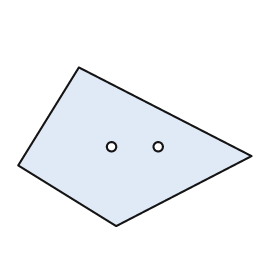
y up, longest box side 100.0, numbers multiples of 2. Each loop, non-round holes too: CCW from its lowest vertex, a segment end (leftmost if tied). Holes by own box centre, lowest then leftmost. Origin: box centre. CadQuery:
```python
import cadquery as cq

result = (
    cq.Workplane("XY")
    .moveTo(-8.0, -34.0)
    .lineTo(50.0, -4.0)
    .lineTo(-24.0, 34.0)
    .lineTo(-50.0, -8.0)
    .close()
    .moveTo(-10.0, 0.0)
    .circle(2.0)
    .moveTo(10.0, 0.0)
    .circle(2.0)
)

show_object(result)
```